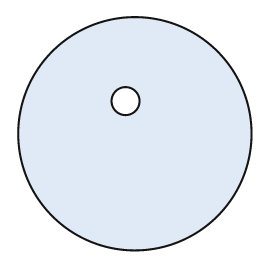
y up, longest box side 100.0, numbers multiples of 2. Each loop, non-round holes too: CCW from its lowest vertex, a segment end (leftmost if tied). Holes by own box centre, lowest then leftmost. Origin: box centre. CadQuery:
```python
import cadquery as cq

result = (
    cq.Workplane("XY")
    .moveTo(0.0, 0.0)
    .circle(50.0)
    .moveTo(-4.0, 14.0)
    .circle(6.0)
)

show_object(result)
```